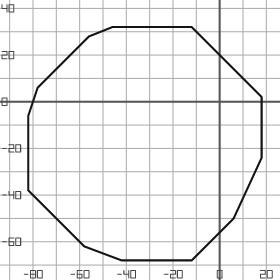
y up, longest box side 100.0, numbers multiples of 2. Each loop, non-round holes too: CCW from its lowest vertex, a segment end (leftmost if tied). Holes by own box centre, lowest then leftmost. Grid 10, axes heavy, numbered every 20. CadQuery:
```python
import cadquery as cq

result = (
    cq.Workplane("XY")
    .moveTo(-42.0, -68.0)
    .lineTo(-12.0, -68.0)
    .lineTo(6.0, -50.0)
    .lineTo(18.0, -24.0)
    .lineTo(18.0, 2.0)
    .lineTo(-12.0, 32.0)
    .lineTo(-46.0, 32.0)
    .lineTo(-56.0, 28.0)
    .lineTo(-78.0, 6.0)
    .lineTo(-82.0, -6.0)
    .lineTo(-82.0, -38.0)
    .lineTo(-58.0, -62.0)
    .close()
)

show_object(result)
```